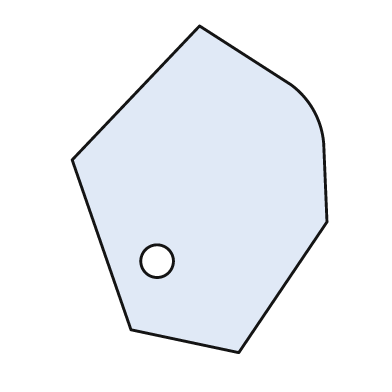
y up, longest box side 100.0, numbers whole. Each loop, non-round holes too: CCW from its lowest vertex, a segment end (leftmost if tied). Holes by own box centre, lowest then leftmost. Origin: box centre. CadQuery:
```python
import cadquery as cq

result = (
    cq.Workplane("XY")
    .moveTo(12.0, -50.0)
    .lineTo(39.0, -10.0)
    .lineTo(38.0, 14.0)
    .threePointArc((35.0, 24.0), (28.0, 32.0))
    .lineTo(0.0, 50.0)
    .lineTo(-39.0, 9.0)
    .lineTo(-21.0, -43.0)
    .close()
    .moveTo(-13.0, -22.0)
    .circle(5.0)
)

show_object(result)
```